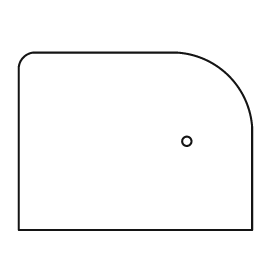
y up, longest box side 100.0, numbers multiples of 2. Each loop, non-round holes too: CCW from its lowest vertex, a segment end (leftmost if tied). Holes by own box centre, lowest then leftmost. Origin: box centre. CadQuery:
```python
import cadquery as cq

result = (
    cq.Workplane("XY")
    .moveTo(-50.0, -38.0)
    .lineTo(50.0, -38.0)
    .lineTo(50.0, 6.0)
    .threePointArc((40.0, 28.0), (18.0, 38.0))
    .lineTo(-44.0, 38.0)
    .threePointArc((-48.0, 36.0), (-50.0, 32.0))
    .close()
    .moveTo(22.0, 0.0)
    .circle(2.0)
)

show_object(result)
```